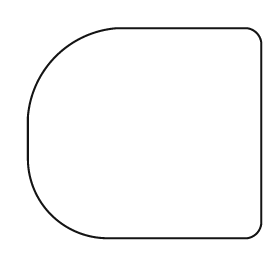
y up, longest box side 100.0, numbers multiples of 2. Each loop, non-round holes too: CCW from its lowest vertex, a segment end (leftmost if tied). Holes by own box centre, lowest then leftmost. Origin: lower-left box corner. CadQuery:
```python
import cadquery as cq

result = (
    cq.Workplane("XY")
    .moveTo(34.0, 0.0)
    .lineTo(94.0, 0.0)
    .threePointArc((98.0, 2.0), (100.0, 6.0))
    .lineTo(100.0, 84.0)
    .threePointArc((98.0, 88.0), (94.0, 90.0))
    .lineTo(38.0, 90.0)
    .threePointArc((12.0, 78.0), (0.0, 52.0))
    .lineTo(0.0, 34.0)
    .threePointArc((10.0, 10.0), (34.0, 0.0))
    .close()
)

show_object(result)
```